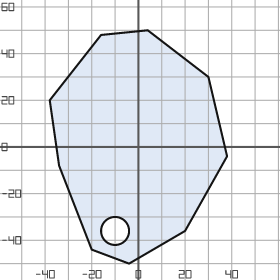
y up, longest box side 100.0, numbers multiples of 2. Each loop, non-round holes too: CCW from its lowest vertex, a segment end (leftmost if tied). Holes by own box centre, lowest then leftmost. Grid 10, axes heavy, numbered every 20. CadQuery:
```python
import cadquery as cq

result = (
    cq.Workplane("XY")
    .moveTo(-4.0, -50.0)
    .lineTo(20.0, -36.0)
    .lineTo(38.0, -4.0)
    .lineTo(30.0, 30.0)
    .lineTo(4.0, 50.0)
    .lineTo(-16.0, 48.0)
    .lineTo(-38.0, 20.0)
    .lineTo(-34.0, -8.0)
    .lineTo(-20.0, -44.0)
    .close()
    .moveTo(-10.0, -36.0)
    .circle(6.0)
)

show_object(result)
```